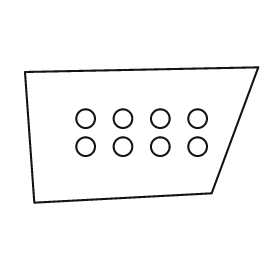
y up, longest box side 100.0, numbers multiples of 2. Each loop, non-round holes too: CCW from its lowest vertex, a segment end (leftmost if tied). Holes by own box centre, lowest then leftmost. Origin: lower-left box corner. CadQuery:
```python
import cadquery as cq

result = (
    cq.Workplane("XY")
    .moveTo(4.0, 0.0)
    .lineTo(80.0, 4.0)
    .lineTo(100.0, 58.0)
    .lineTo(0.0, 56.0)
    .close()
    .moveTo(26.0, 24.0)
    .circle(4.0)
    .moveTo(42.0, 24.0)
    .circle(4.0)
    .moveTo(58.0, 24.0)
    .circle(4.0)
    .moveTo(74.0, 24.0)
    .circle(4.0)
    .moveTo(26.0, 36.0)
    .circle(4.0)
    .moveTo(42.0, 36.0)
    .circle(4.0)
    .moveTo(58.0, 36.0)
    .circle(4.0)
    .moveTo(74.0, 36.0)
    .circle(4.0)
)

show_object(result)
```